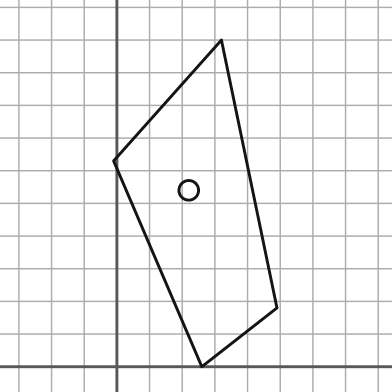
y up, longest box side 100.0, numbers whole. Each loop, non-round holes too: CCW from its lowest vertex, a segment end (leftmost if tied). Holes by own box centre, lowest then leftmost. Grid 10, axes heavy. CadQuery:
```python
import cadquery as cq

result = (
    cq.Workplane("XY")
    .moveTo(26.0, 0.0)
    .lineTo(49.0, 18.0)
    .lineTo(32.0, 100.0)
    .lineTo(-1.0, 63.0)
    .close()
    .moveTo(22.0, 54.0)
    .circle(3.0)
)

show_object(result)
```